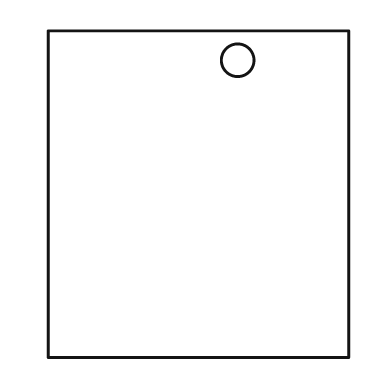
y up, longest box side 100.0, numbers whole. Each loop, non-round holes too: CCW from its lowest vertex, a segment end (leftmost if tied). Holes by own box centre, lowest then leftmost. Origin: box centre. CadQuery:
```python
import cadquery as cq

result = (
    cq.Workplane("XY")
    .moveTo(-46.0, -50.0)
    .lineTo(46.0, -50.0)
    .lineTo(46.0, 50.0)
    .lineTo(-46.0, 50.0)
    .close()
    .moveTo(12.0, 41.0)
    .circle(5.0)
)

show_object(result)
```